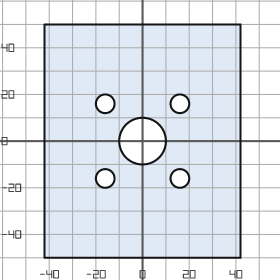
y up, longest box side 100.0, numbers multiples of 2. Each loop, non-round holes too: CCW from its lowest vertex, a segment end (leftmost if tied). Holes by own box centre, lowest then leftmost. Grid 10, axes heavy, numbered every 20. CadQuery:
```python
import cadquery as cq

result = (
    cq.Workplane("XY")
    .moveTo(-42.0, -50.0)
    .lineTo(42.0, -50.0)
    .lineTo(42.0, 50.0)
    .lineTo(-42.0, 50.0)
    .close()
    .moveTo(-16.0, -16.0)
    .circle(4.0)
    .moveTo(16.0, -16.0)
    .circle(4.0)
    .moveTo(0.0, 0.0)
    .circle(10.0)
    .moveTo(-16.0, 16.0)
    .circle(4.0)
    .moveTo(16.0, 16.0)
    .circle(4.0)
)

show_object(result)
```